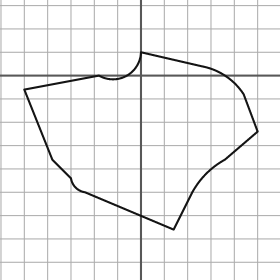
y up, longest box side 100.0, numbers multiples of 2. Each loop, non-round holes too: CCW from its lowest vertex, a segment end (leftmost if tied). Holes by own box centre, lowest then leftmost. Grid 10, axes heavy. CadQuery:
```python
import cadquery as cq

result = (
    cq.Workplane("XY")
    .moveTo(14.0, -66.0)
    .lineTo(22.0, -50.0)
    .threePointArc((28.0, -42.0), (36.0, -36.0))
    .lineTo(50.0, -24.0)
    .lineTo(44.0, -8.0)
    .threePointArc((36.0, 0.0), (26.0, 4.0))
    .lineTo(0.0, 10.0)
    .threePointArc((-6.0, 0.0), (-18.0, 0.0))
    .lineTo(-50.0, -6.0)
    .lineTo(-38.0, -36.0)
    .lineTo(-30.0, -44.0)
    .threePointArc((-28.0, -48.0), (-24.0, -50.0))
    .close()
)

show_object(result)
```